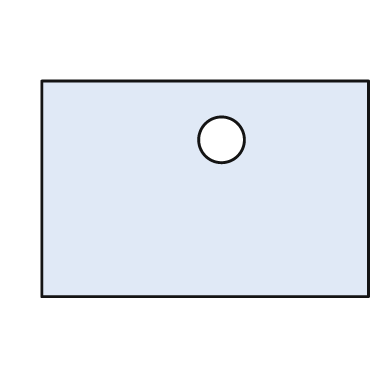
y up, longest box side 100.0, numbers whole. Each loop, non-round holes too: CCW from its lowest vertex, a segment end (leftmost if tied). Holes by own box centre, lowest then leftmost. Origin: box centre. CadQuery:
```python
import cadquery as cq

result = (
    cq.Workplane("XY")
    .moveTo(-50.0, -33.0)
    .lineTo(50.0, -33.0)
    .lineTo(50.0, 33.0)
    .lineTo(-50.0, 33.0)
    .close()
    .moveTo(5.0, 15.0)
    .circle(7.0)
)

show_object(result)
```